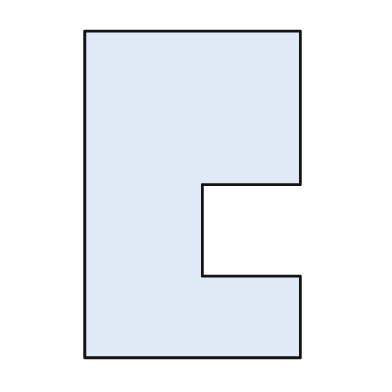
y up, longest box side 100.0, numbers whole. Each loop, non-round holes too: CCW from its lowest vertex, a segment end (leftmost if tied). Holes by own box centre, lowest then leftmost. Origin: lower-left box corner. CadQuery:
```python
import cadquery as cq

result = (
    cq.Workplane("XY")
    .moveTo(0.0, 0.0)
    .lineTo(66.0, 0.0)
    .lineTo(66.0, 25.0)
    .lineTo(36.0, 25.0)
    .lineTo(36.0, 53.0)
    .lineTo(66.0, 53.0)
    .lineTo(66.0, 100.0)
    .lineTo(0.0, 100.0)
    .close()
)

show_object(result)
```